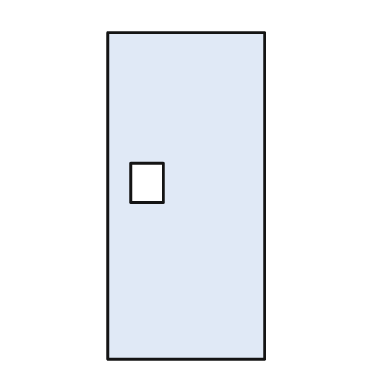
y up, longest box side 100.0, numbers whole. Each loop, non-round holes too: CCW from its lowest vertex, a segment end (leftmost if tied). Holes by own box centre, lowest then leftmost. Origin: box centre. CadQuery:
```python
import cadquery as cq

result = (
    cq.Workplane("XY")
    .moveTo(-24.0, -50.0)
    .lineTo(24.0, -50.0)
    .lineTo(24.0, 50.0)
    .lineTo(-24.0, 50.0)
    .close()
    .moveTo(-17.0, -2.0)
    .lineTo(-7.0, -2.0)
    .lineTo(-7.0, 10.0)
    .lineTo(-17.0, 10.0)
    .close()
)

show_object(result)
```